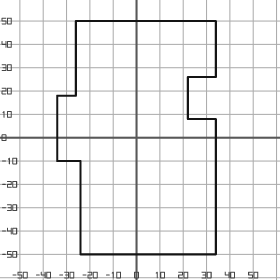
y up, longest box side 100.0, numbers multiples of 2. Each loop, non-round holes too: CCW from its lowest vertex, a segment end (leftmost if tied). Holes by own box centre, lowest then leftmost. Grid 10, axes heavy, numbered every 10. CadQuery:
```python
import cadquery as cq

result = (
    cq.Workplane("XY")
    .moveTo(-24.0, -50.0)
    .lineTo(34.0, -50.0)
    .lineTo(34.0, 8.0)
    .lineTo(22.0, 8.0)
    .lineTo(22.0, 26.0)
    .lineTo(34.0, 26.0)
    .lineTo(34.0, 50.0)
    .lineTo(-26.0, 50.0)
    .lineTo(-26.0, 18.0)
    .lineTo(-34.0, 18.0)
    .lineTo(-34.0, -10.0)
    .lineTo(-24.0, -10.0)
    .close()
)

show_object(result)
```